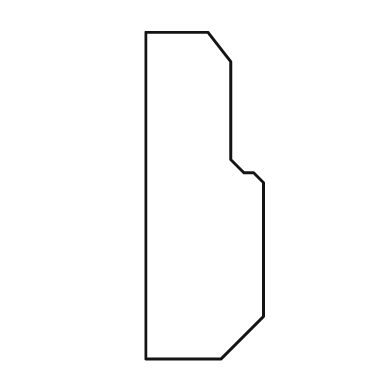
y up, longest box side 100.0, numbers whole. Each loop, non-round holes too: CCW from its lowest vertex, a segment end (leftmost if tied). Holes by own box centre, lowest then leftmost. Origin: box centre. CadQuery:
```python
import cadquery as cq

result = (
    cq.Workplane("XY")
    .moveTo(-18.0, -50.0)
    .lineTo(5.0, -50.0)
    .lineTo(18.0, -37.0)
    .lineTo(18.0, 4.0)
    .lineTo(15.0, 7.0)
    .lineTo(12.0, 7.0)
    .lineTo(8.0, 11.0)
    .lineTo(8.0, 41.0)
    .lineTo(1.0, 50.0)
    .lineTo(-18.0, 50.0)
    .close()
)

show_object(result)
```